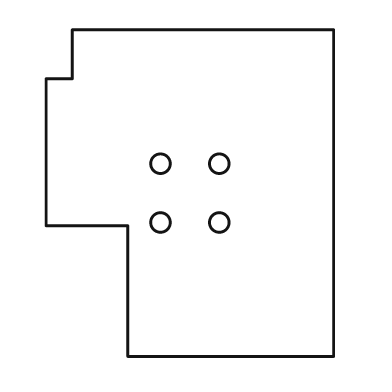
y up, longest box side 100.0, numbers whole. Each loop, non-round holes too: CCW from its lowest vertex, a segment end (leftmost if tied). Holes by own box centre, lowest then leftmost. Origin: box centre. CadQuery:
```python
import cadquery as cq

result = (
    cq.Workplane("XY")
    .moveTo(-19.0, -50.0)
    .lineTo(44.0, -50.0)
    .lineTo(44.0, 50.0)
    .lineTo(-36.0, 50.0)
    .lineTo(-36.0, 35.0)
    .lineTo(-44.0, 35.0)
    .lineTo(-44.0, -10.0)
    .lineTo(-19.0, -10.0)
    .close()
    .moveTo(-9.0, -9.0)
    .circle(3.0)
    .moveTo(9.0, -9.0)
    .circle(3.0)
    .moveTo(-9.0, 9.0)
    .circle(3.0)
    .moveTo(9.0, 9.0)
    .circle(3.0)
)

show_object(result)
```